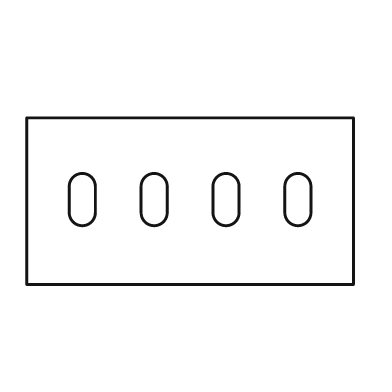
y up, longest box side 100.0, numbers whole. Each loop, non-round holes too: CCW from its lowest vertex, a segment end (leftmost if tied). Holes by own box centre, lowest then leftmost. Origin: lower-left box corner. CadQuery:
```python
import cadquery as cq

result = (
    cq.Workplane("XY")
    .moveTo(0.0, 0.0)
    .lineTo(100.0, 0.0)
    .lineTo(100.0, 51.0)
    .lineTo(0.0, 51.0)
    .close()
    .moveTo(13.0, 22.0)
    .threePointArc((17.0, 18.0), (21.0, 22.0))
    .lineTo(21.0, 30.0)
    .threePointArc((17.0, 34.0), (13.0, 30.0))
    .close()
    .moveTo(35.0, 22.0)
    .threePointArc((39.0, 18.0), (43.0, 22.0))
    .lineTo(43.0, 30.0)
    .threePointArc((39.0, 34.0), (35.0, 30.0))
    .close()
    .moveTo(57.0, 22.0)
    .threePointArc((61.0, 18.0), (65.0, 22.0))
    .lineTo(65.0, 30.0)
    .threePointArc((61.0, 34.0), (57.0, 30.0))
    .close()
    .moveTo(79.0, 22.0)
    .threePointArc((83.0, 18.0), (87.0, 22.0))
    .lineTo(87.0, 30.0)
    .threePointArc((83.0, 34.0), (79.0, 30.0))
    .close()
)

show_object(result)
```